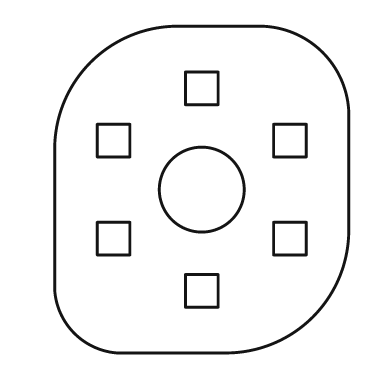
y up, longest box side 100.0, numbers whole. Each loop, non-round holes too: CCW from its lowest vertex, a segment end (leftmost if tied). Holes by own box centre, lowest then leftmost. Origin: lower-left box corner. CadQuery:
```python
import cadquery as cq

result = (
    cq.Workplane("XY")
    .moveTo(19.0, 0.0)
    .lineTo(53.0, 0.0)
    .threePointArc((79.0, 11.0), (90.0, 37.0))
    .lineTo(90.0, 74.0)
    .threePointArc((82.0, 92.0), (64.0, 100.0))
    .lineTo(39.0, 100.0)
    .threePointArc((11.0, 89.0), (0.0, 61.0))
    .lineTo(0.0, 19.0)
    .threePointArc((6.0, 6.0), (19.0, 0.0))
    .close()
    .moveTo(40.0, 14.0)
    .lineTo(50.0, 14.0)
    .lineTo(50.0, 24.0)
    .lineTo(40.0, 24.0)
    .close()
    .moveTo(13.0, 30.0)
    .lineTo(23.0, 30.0)
    .lineTo(23.0, 40.0)
    .lineTo(13.0, 40.0)
    .close()
    .moveTo(67.0, 30.0)
    .lineTo(77.0, 30.0)
    .lineTo(77.0, 40.0)
    .lineTo(67.0, 40.0)
    .close()
    .moveTo(45.0, 50.0)
    .circle(13.0)
    .moveTo(13.0, 60.0)
    .lineTo(23.0, 60.0)
    .lineTo(23.0, 70.0)
    .lineTo(13.0, 70.0)
    .close()
    .moveTo(67.0, 60.0)
    .lineTo(77.0, 60.0)
    .lineTo(77.0, 70.0)
    .lineTo(67.0, 70.0)
    .close()
    .moveTo(40.0, 76.0)
    .lineTo(50.0, 76.0)
    .lineTo(50.0, 86.0)
    .lineTo(40.0, 86.0)
    .close()
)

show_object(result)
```